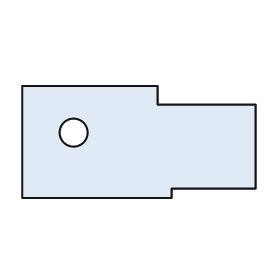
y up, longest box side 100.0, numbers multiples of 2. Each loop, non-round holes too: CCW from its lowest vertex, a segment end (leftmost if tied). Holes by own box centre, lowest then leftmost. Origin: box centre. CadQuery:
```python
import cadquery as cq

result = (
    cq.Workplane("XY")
    .moveTo(-50.0, -24.0)
    .lineTo(14.0, -24.0)
    .lineTo(14.0, -20.0)
    .lineTo(50.0, -20.0)
    .lineTo(50.0, 16.0)
    .lineTo(8.0, 16.0)
    .lineTo(8.0, 24.0)
    .lineTo(-50.0, 24.0)
    .close()
    .moveTo(-28.0, 4.0)
    .circle(6.0)
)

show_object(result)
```